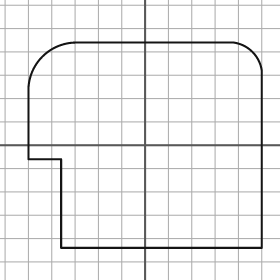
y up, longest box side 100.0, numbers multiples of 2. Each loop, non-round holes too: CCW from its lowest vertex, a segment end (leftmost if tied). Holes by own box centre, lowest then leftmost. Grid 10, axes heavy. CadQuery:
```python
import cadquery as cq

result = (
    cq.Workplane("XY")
    .moveTo(-36.0, -44.0)
    .lineTo(50.0, -44.0)
    .lineTo(50.0, 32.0)
    .threePointArc((46.0, 40.0), (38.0, 44.0))
    .lineTo(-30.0, 44.0)
    .threePointArc((-44.0, 38.0), (-50.0, 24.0))
    .lineTo(-50.0, -6.0)
    .lineTo(-36.0, -6.0)
    .close()
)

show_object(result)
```